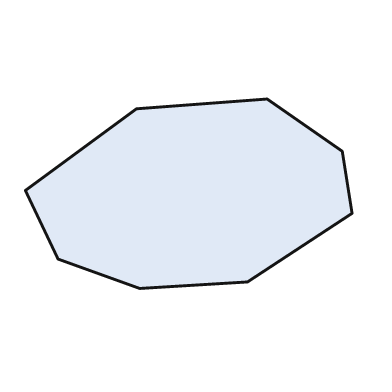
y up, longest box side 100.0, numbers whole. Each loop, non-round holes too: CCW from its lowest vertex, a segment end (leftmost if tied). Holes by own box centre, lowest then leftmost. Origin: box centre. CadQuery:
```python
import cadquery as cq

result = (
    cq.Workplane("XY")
    .moveTo(-15.0, -29.0)
    .lineTo(18.0, -27.0)
    .lineTo(50.0, -6.0)
    .lineTo(47.0, 13.0)
    .lineTo(24.0, 29.0)
    .lineTo(-16.0, 26.0)
    .lineTo(-50.0, 1.0)
    .lineTo(-40.0, -20.0)
    .close()
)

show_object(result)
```